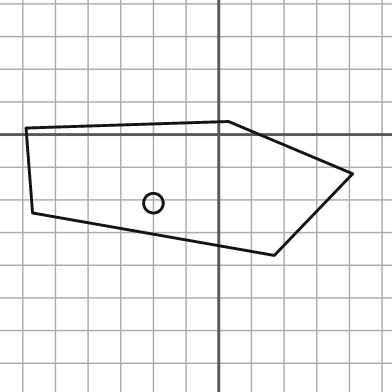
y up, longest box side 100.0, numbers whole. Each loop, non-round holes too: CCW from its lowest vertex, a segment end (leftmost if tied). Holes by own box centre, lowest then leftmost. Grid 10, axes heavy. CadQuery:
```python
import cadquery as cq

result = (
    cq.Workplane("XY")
    .moveTo(17.0, -37.0)
    .lineTo(41.0, -12.0)
    .lineTo(3.0, 4.0)
    .lineTo(-59.0, 2.0)
    .lineTo(-57.0, -24.0)
    .close()
    .moveTo(-20.0, -21.0)
    .circle(3.0)
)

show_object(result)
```